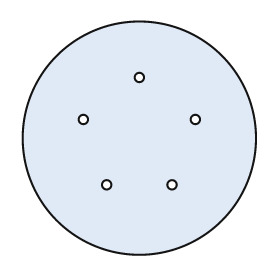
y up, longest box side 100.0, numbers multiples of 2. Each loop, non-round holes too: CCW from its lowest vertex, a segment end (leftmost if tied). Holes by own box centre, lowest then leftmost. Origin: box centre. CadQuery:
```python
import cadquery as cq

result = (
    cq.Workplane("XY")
    .moveTo(0.0, 0.0)
    .circle(50.0)
    .moveTo(-14.0, -20.0)
    .circle(2.0)
    .moveTo(14.0, -20.0)
    .circle(2.0)
    .moveTo(-24.0, 8.0)
    .circle(2.0)
    .moveTo(24.0, 8.0)
    .circle(2.0)
    .moveTo(0.0, 26.0)
    .circle(2.0)
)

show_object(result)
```